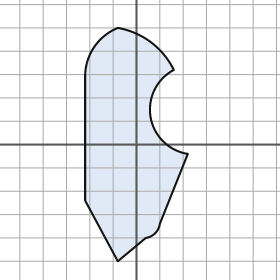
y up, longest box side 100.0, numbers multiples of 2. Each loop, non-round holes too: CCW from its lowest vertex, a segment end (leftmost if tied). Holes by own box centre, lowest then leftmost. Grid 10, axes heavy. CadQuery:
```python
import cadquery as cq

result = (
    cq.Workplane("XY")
    .moveTo(-8.0, -50.0)
    .lineTo(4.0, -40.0)
    .threePointArc((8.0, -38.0), (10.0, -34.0))
    .lineTo(22.0, -4.0)
    .threePointArc((6.0, 12.0), (16.0, 32.0))
    .threePointArc((6.0, 44.0), (-8.0, 50.0))
    .threePointArc((-18.0, 42.0), (-22.0, 30.0))
    .lineTo(-22.0, -24.0)
    .close()
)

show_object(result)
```